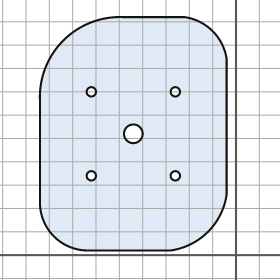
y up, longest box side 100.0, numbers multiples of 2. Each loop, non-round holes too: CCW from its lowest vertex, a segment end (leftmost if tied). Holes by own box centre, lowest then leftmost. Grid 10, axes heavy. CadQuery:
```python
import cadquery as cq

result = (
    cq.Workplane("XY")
    .moveTo(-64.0, 2.0)
    .lineTo(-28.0, 2.0)
    .threePointArc((-12.0, 10.0), (-4.0, 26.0))
    .lineTo(-4.0, 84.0)
    .threePointArc((-10.0, 96.0), (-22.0, 102.0))
    .lineTo(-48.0, 102.0)
    .threePointArc((-74.0, 92.0), (-84.0, 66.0))
    .lineTo(-84.0, 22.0)
    .threePointArc((-78.0, 8.0), (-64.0, 2.0))
    .close()
    .moveTo(-62.0, 34.0)
    .circle(2.0)
    .moveTo(-26.0, 34.0)
    .circle(2.0)
    .moveTo(-44.0, 52.0)
    .circle(4.0)
    .moveTo(-62.0, 70.0)
    .circle(2.0)
    .moveTo(-26.0, 70.0)
    .circle(2.0)
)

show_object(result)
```